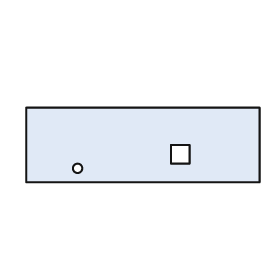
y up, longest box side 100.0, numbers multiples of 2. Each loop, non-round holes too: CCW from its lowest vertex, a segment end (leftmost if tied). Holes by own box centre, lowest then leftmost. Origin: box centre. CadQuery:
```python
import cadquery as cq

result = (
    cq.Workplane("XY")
    .moveTo(-50.0, -16.0)
    .lineTo(50.0, -16.0)
    .lineTo(50.0, 16.0)
    .lineTo(-50.0, 16.0)
    .close()
    .moveTo(-28.0, -10.0)
    .circle(2.0)
    .moveTo(12.0, -8.0)
    .lineTo(20.0, -8.0)
    .lineTo(20.0, 0.0)
    .lineTo(12.0, 0.0)
    .close()
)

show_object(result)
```